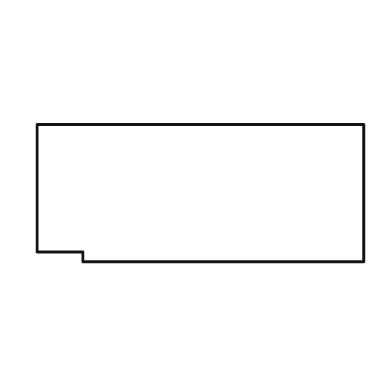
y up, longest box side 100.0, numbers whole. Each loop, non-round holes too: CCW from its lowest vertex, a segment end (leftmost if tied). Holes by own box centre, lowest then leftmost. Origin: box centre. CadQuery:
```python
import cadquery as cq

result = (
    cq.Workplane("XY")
    .moveTo(-36.0, -21.0)
    .lineTo(50.0, -21.0)
    .lineTo(50.0, 21.0)
    .lineTo(-50.0, 21.0)
    .lineTo(-50.0, -18.0)
    .lineTo(-36.0, -18.0)
    .close()
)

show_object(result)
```